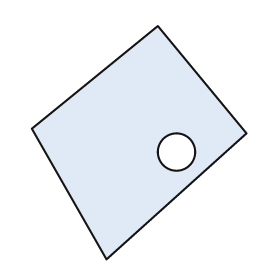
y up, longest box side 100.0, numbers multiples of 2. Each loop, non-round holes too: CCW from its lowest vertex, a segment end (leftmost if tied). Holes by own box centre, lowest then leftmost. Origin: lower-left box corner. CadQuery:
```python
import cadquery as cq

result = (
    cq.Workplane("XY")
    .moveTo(32.0, 0.0)
    .lineTo(92.0, 54.0)
    .lineTo(54.0, 100.0)
    .lineTo(0.0, 56.0)
    .close()
    .moveTo(62.0, 46.0)
    .circle(8.0)
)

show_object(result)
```